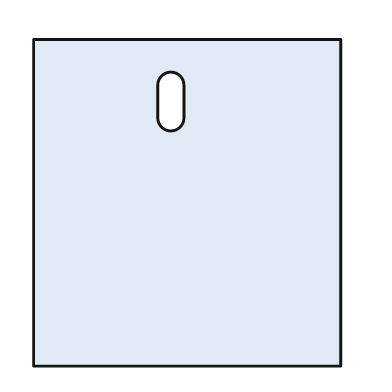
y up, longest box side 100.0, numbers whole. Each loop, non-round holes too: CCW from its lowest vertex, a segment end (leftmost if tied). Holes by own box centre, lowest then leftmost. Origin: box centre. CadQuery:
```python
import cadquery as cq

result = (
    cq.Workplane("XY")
    .moveTo(-47.0, -50.0)
    .lineTo(47.0, -50.0)
    .lineTo(47.0, 50.0)
    .lineTo(-47.0, 50.0)
    .close()
    .moveTo(-9.0, 26.0)
    .threePointArc((-5.0, 22.0), (-1.0, 26.0))
    .lineTo(-1.0, 36.0)
    .threePointArc((-5.0, 40.0), (-9.0, 36.0))
    .close()
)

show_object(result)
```